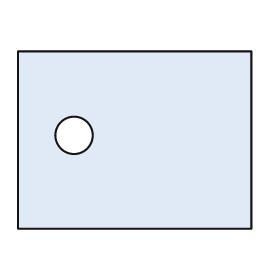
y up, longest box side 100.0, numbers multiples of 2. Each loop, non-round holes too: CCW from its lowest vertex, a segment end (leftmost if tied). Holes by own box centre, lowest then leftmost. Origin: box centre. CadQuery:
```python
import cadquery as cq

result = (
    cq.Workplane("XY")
    .moveTo(-50.0, -38.0)
    .lineTo(50.0, -38.0)
    .lineTo(50.0, 38.0)
    .lineTo(-50.0, 38.0)
    .close()
    .moveTo(-26.0, 2.0)
    .circle(8.0)
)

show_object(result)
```